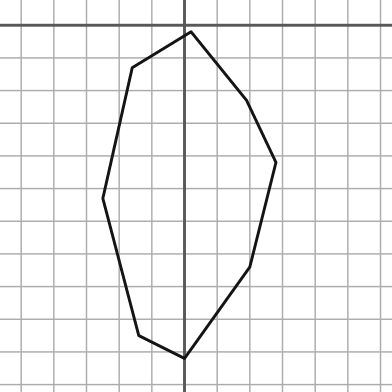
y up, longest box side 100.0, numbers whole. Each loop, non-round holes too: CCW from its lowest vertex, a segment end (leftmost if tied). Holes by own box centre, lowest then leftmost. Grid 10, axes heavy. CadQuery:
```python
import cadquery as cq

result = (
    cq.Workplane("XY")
    .moveTo(0.0, -102.0)
    .lineTo(20.0, -74.0)
    .lineTo(28.0, -42.0)
    .lineTo(19.0, -23.0)
    .lineTo(2.0, -2.0)
    .lineTo(-16.0, -13.0)
    .lineTo(-25.0, -53.0)
    .lineTo(-14.0, -95.0)
    .close()
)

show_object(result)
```